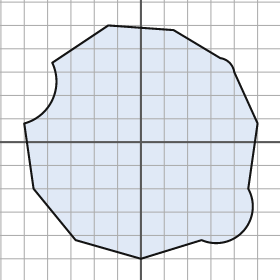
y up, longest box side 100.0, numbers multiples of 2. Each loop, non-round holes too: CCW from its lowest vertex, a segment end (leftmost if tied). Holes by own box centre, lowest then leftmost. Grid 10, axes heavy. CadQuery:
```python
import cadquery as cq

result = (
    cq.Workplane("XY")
    .moveTo(0.0, -50.0)
    .lineTo(26.0, -42.0)
    .threePointArc((44.0, -38.0), (46.0, -20.0))
    .lineTo(50.0, 8.0)
    .lineTo(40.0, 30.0)
    .threePointArc((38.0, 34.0), (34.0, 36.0))
    .lineTo(14.0, 48.0)
    .lineTo(-14.0, 50.0)
    .lineTo(-38.0, 34.0)
    .threePointArc((-38.0, 18.0), (-50.0, 8.0))
    .lineTo(-46.0, -20.0)
    .lineTo(-28.0, -42.0)
    .close()
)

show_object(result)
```